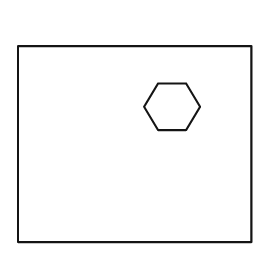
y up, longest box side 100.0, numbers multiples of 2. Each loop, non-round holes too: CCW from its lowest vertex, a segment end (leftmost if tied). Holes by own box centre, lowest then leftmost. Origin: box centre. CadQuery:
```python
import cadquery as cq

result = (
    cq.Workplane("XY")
    .moveTo(-50.0, -42.0)
    .lineTo(50.0, -42.0)
    .lineTo(50.0, 42.0)
    .lineTo(-50.0, 42.0)
    .close()
    .moveTo(10.0, 6.0)
    .lineTo(22.0, 6.0)
    .lineTo(28.0, 16.0)
    .lineTo(22.0, 26.0)
    .lineTo(10.0, 26.0)
    .lineTo(4.0, 16.0)
    .close()
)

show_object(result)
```